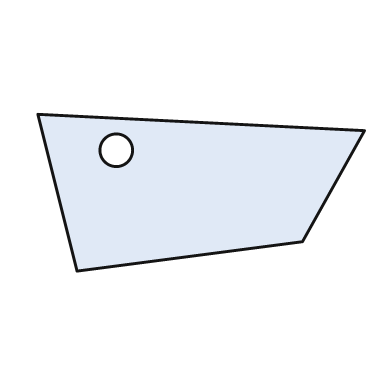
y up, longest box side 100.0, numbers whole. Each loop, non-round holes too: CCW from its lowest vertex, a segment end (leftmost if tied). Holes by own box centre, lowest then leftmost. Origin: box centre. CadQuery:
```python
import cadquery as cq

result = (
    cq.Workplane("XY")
    .moveTo(-38.0, -24.0)
    .lineTo(31.0, -15.0)
    .lineTo(50.0, 19.0)
    .lineTo(-50.0, 24.0)
    .close()
    .moveTo(-26.0, 13.0)
    .circle(5.0)
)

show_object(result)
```